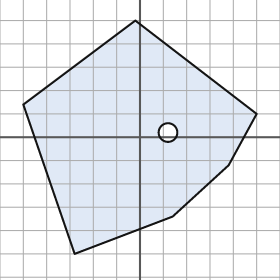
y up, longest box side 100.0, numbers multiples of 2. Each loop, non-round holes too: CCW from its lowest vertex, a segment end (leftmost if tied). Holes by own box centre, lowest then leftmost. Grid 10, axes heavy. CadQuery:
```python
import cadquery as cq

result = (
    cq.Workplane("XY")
    .moveTo(-28.0, -50.0)
    .lineTo(14.0, -34.0)
    .lineTo(38.0, -12.0)
    .lineTo(50.0, 10.0)
    .lineTo(-2.0, 50.0)
    .lineTo(-50.0, 14.0)
    .close()
    .moveTo(12.0, 2.0)
    .circle(4.0)
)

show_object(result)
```